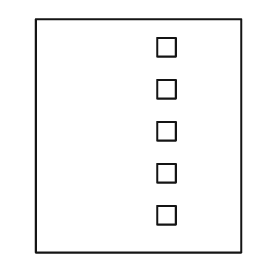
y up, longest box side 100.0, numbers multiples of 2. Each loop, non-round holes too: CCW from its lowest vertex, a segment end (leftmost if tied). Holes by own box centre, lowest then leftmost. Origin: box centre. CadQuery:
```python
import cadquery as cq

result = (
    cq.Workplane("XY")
    .moveTo(-44.0, -50.0)
    .lineTo(44.0, -50.0)
    .lineTo(44.0, 50.0)
    .lineTo(-44.0, 50.0)
    .close()
    .moveTo(8.0, -38.0)
    .lineTo(16.0, -38.0)
    .lineTo(16.0, -30.0)
    .lineTo(8.0, -30.0)
    .close()
    .moveTo(8.0, -20.0)
    .lineTo(16.0, -20.0)
    .lineTo(16.0, -12.0)
    .lineTo(8.0, -12.0)
    .close()
    .moveTo(8.0, -2.0)
    .lineTo(16.0, -2.0)
    .lineTo(16.0, 6.0)
    .lineTo(8.0, 6.0)
    .close()
    .moveTo(8.0, 16.0)
    .lineTo(16.0, 16.0)
    .lineTo(16.0, 24.0)
    .lineTo(8.0, 24.0)
    .close()
    .moveTo(8.0, 34.0)
    .lineTo(16.0, 34.0)
    .lineTo(16.0, 42.0)
    .lineTo(8.0, 42.0)
    .close()
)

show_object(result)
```